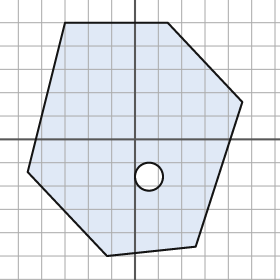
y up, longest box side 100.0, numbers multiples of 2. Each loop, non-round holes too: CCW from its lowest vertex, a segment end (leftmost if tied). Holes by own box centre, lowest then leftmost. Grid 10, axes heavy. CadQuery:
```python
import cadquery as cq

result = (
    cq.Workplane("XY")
    .moveTo(-12.0, -50.0)
    .lineTo(26.0, -46.0)
    .lineTo(46.0, 16.0)
    .lineTo(14.0, 50.0)
    .lineTo(-30.0, 50.0)
    .lineTo(-46.0, -14.0)
    .close()
    .moveTo(6.0, -16.0)
    .circle(6.0)
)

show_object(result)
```